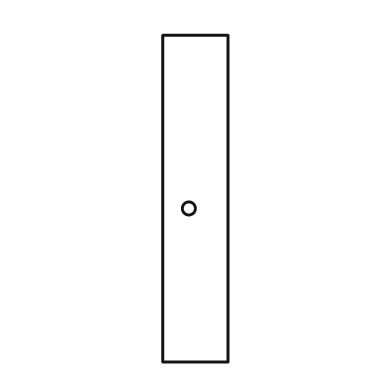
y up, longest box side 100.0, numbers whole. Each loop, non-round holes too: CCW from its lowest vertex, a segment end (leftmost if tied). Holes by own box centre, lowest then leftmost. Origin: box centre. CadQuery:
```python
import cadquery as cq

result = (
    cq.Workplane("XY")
    .moveTo(-10.0, -50.0)
    .lineTo(10.0, -50.0)
    .lineTo(10.0, 50.0)
    .lineTo(-10.0, 50.0)
    .close()
    .moveTo(-2.0, -3.0)
    .circle(2.0)
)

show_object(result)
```